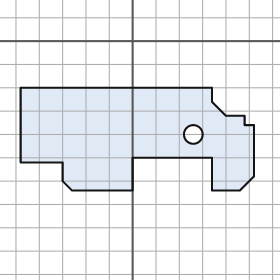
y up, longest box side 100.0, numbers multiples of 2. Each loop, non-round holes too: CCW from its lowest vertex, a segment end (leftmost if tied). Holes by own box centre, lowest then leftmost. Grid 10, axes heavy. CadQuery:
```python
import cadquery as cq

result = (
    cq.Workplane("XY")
    .moveTo(-26.0, -64.0)
    .lineTo(0.0, -64.0)
    .lineTo(0.0, -50.0)
    .lineTo(34.0, -50.0)
    .lineTo(34.0, -64.0)
    .lineTo(46.0, -64.0)
    .lineTo(52.0, -58.0)
    .lineTo(52.0, -36.0)
    .lineTo(48.0, -36.0)
    .lineTo(48.0, -32.0)
    .lineTo(40.0, -32.0)
    .lineTo(34.0, -26.0)
    .lineTo(34.0, -20.0)
    .lineTo(-48.0, -20.0)
    .lineTo(-48.0, -52.0)
    .lineTo(-30.0, -52.0)
    .lineTo(-30.0, -60.0)
    .close()
    .moveTo(26.0, -40.0)
    .circle(4.0)
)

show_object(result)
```